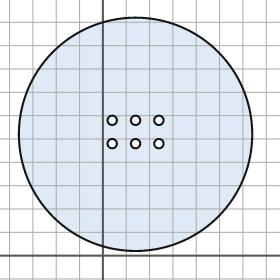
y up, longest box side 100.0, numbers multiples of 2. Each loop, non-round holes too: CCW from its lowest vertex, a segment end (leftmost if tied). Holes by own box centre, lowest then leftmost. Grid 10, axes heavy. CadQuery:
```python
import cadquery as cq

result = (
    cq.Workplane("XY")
    .moveTo(14.0, 52.0)
    .circle(50.0)
    .moveTo(4.0, 48.0)
    .circle(2.0)
    .moveTo(14.0, 48.0)
    .circle(2.0)
    .moveTo(24.0, 48.0)
    .circle(2.0)
    .moveTo(4.0, 58.0)
    .circle(2.0)
    .moveTo(14.0, 58.0)
    .circle(2.0)
    .moveTo(24.0, 58.0)
    .circle(2.0)
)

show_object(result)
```